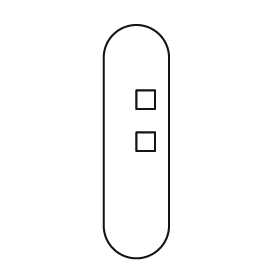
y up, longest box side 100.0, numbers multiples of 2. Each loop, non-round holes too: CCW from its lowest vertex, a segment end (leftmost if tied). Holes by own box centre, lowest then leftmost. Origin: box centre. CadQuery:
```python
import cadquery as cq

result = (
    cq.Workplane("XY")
    .moveTo(-14.0, -36.0)
    .threePointArc((0.0, -50.0), (14.0, -36.0))
    .lineTo(14.0, 36.0)
    .threePointArc((0.0, 50.0), (-14.0, 36.0))
    .close()
    .moveTo(0.0, -4.0)
    .lineTo(8.0, -4.0)
    .lineTo(8.0, 4.0)
    .lineTo(0.0, 4.0)
    .close()
    .moveTo(0.0, 14.0)
    .lineTo(8.0, 14.0)
    .lineTo(8.0, 22.0)
    .lineTo(0.0, 22.0)
    .close()
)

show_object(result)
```